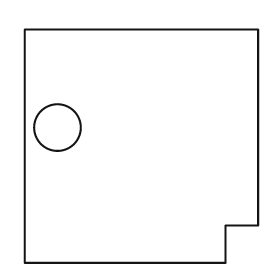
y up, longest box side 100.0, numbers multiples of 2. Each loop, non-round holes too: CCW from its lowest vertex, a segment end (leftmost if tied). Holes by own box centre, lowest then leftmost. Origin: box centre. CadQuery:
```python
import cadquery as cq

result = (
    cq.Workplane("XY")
    .moveTo(-50.0, -50.0)
    .lineTo(36.0, -50.0)
    .lineTo(36.0, -34.0)
    .lineTo(50.0, -34.0)
    .lineTo(50.0, 50.0)
    .lineTo(-50.0, 50.0)
    .close()
    .moveTo(-36.0, 8.0)
    .circle(10.0)
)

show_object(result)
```